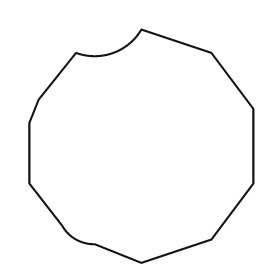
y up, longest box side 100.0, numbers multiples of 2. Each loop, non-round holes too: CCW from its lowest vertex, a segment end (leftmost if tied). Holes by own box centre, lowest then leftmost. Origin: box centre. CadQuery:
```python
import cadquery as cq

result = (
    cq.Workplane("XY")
    .moveTo(0.0, -50.0)
    .lineTo(30.0, -40.0)
    .lineTo(48.0, -16.0)
    .lineTo(48.0, 16.0)
    .lineTo(30.0, 40.0)
    .lineTo(0.0, 50.0)
    .threePointArc((-12.0, 40.0), (-28.0, 40.0))
    .lineTo(-44.0, 20.0)
    .lineTo(-48.0, 10.0)
    .lineTo(-48.0, -16.0)
    .lineTo(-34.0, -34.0)
    .threePointArc((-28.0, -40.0), (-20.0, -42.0))
    .close()
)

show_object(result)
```